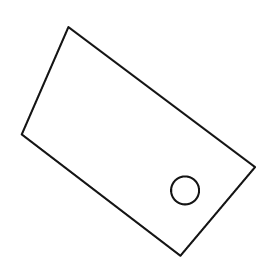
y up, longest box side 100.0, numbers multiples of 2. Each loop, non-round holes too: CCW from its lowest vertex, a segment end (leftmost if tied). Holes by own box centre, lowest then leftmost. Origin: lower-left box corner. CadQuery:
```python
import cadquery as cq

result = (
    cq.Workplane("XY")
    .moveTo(68.0, 0.0)
    .lineTo(100.0, 38.0)
    .lineTo(20.0, 98.0)
    .lineTo(0.0, 52.0)
    .close()
    .moveTo(70.0, 28.0)
    .circle(6.0)
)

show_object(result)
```